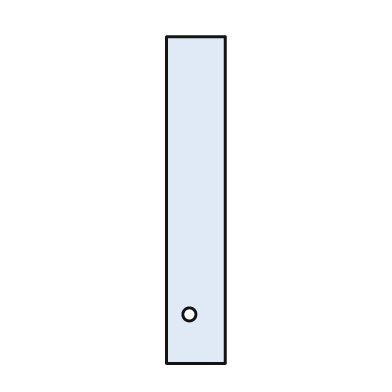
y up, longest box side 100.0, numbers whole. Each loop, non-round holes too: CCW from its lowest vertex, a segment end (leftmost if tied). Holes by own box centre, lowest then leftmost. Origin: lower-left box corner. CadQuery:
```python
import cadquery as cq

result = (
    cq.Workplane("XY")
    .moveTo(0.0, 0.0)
    .lineTo(18.0, 0.0)
    .lineTo(18.0, 100.0)
    .lineTo(0.0, 100.0)
    .close()
    .moveTo(7.0, 15.0)
    .circle(2.0)
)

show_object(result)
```